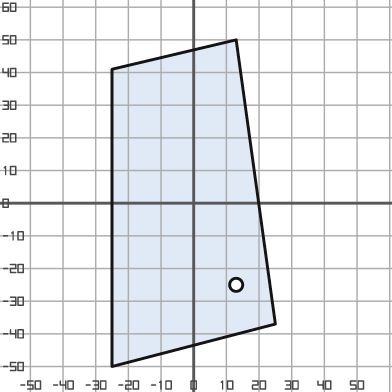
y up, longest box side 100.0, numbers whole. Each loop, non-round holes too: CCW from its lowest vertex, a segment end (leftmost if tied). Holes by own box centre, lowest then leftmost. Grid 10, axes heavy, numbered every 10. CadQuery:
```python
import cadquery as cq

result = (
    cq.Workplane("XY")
    .moveTo(-25.0, -50.0)
    .lineTo(25.0, -37.0)
    .lineTo(13.0, 50.0)
    .lineTo(-25.0, 41.0)
    .close()
    .moveTo(13.0, -25.0)
    .circle(2.0)
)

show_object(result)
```